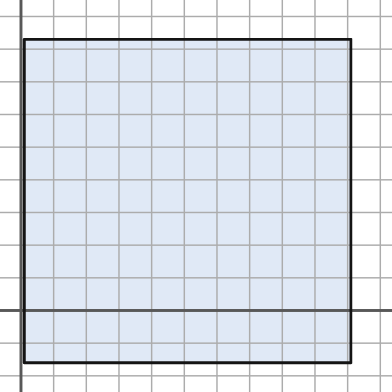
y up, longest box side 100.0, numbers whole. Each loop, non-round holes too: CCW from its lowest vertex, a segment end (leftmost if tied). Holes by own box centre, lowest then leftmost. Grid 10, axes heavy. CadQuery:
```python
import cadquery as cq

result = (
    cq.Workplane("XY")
    .moveTo(1.0, -16.0)
    .lineTo(101.0, -16.0)
    .lineTo(101.0, 83.0)
    .lineTo(1.0, 83.0)
    .close()
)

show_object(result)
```